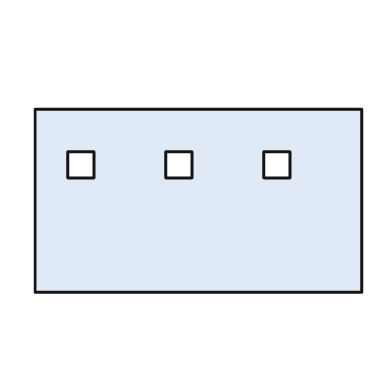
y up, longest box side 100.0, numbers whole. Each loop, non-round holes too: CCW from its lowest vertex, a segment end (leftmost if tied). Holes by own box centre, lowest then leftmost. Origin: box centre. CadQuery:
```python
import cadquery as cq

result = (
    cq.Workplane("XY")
    .moveTo(-50.0, -28.0)
    .lineTo(50.0, -28.0)
    .lineTo(50.0, 28.0)
    .lineTo(-50.0, 28.0)
    .close()
    .moveTo(-40.0, 7.0)
    .lineTo(-32.0, 7.0)
    .lineTo(-32.0, 15.0)
    .lineTo(-40.0, 15.0)
    .close()
    .moveTo(-10.0, 7.0)
    .lineTo(-2.0, 7.0)
    .lineTo(-2.0, 15.0)
    .lineTo(-10.0, 15.0)
    .close()
    .moveTo(20.0, 7.0)
    .lineTo(28.0, 7.0)
    .lineTo(28.0, 15.0)
    .lineTo(20.0, 15.0)
    .close()
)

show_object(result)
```